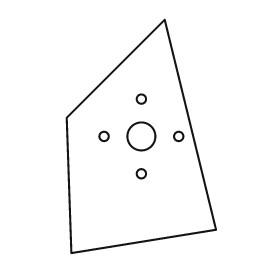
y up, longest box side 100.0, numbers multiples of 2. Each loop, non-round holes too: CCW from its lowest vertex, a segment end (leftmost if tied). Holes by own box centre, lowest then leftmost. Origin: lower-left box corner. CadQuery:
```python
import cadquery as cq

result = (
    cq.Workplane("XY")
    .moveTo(2.0, 0.0)
    .lineTo(64.0, 10.0)
    .lineTo(42.0, 100.0)
    .lineTo(0.0, 58.0)
    .close()
    .moveTo(32.0, 34.0)
    .circle(2.0)
    .moveTo(16.0, 50.0)
    .circle(2.0)
    .moveTo(32.0, 50.0)
    .circle(6.0)
    .moveTo(48.0, 50.0)
    .circle(2.0)
    .moveTo(32.0, 66.0)
    .circle(2.0)
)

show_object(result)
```